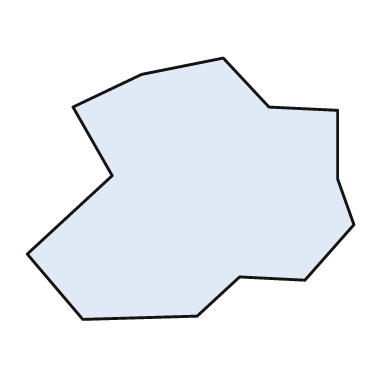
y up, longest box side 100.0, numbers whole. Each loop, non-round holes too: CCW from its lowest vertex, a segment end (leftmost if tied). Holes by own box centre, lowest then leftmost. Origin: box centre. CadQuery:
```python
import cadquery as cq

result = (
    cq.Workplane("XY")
    .moveTo(-33.0, -40.0)
    .lineTo(2.0, -39.0)
    .lineTo(15.0, -27.0)
    .lineTo(35.0, -28.0)
    .lineTo(50.0, -11.0)
    .lineTo(45.0, 3.0)
    .lineTo(45.0, 24.0)
    .lineTo(24.0, 25.0)
    .lineTo(10.0, 40.0)
    .lineTo(-15.0, 35.0)
    .lineTo(-36.0, 25.0)
    .lineTo(-24.0, 4.0)
    .lineTo(-50.0, -20.0)
    .close()
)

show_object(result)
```